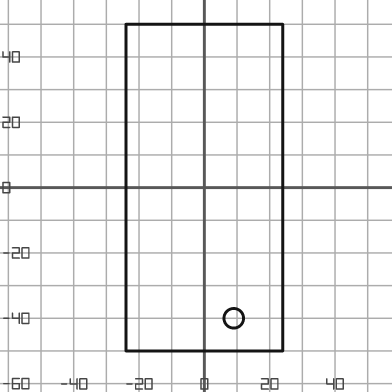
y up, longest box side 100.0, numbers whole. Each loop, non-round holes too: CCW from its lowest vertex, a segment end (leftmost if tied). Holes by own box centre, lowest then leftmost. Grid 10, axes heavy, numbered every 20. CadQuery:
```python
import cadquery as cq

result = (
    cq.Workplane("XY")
    .moveTo(-24.0, -50.0)
    .lineTo(24.0, -50.0)
    .lineTo(24.0, 50.0)
    .lineTo(-24.0, 50.0)
    .close()
    .moveTo(9.0, -40.0)
    .circle(3.0)
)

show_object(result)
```